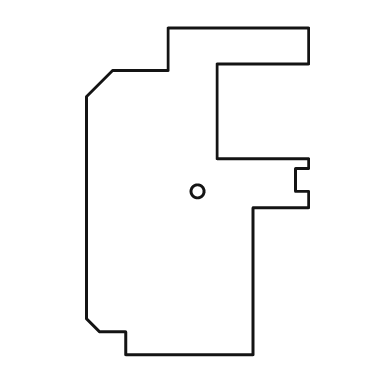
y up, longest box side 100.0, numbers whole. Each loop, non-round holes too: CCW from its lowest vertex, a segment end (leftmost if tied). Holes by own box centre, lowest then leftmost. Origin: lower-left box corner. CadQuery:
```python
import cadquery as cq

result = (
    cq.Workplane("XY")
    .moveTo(12.0, 0.0)
    .lineTo(51.0, 0.0)
    .lineTo(51.0, 45.0)
    .lineTo(68.0, 45.0)
    .lineTo(68.0, 50.0)
    .lineTo(64.0, 50.0)
    .lineTo(64.0, 57.0)
    .lineTo(68.0, 57.0)
    .lineTo(68.0, 60.0)
    .lineTo(40.0, 60.0)
    .lineTo(40.0, 89.0)
    .lineTo(68.0, 89.0)
    .lineTo(68.0, 100.0)
    .lineTo(25.0, 100.0)
    .lineTo(25.0, 87.0)
    .lineTo(8.0, 87.0)
    .lineTo(0.0, 79.0)
    .lineTo(0.0, 11.0)
    .lineTo(4.0, 7.0)
    .lineTo(12.0, 7.0)
    .close()
    .moveTo(34.0, 50.0)
    .circle(2.0)
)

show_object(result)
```